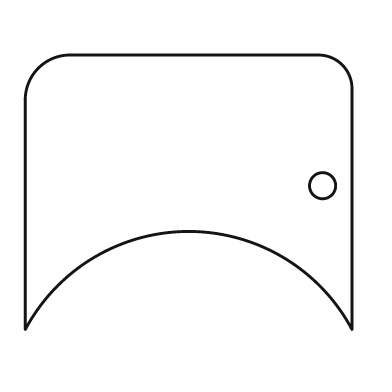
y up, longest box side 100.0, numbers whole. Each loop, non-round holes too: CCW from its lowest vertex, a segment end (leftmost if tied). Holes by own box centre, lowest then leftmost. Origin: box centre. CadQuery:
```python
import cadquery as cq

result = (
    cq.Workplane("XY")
    .moveTo(-50.0, -42.0)
    .threePointArc((0.0, -12.0), (50.0, -42.0))
    .lineTo(50.0, 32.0)
    .threePointArc((47.0, 39.0), (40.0, 42.0))
    .lineTo(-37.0, 42.0)
    .threePointArc((-46.0, 38.0), (-50.0, 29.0))
    .close()
    .moveTo(41.0, 2.0)
    .circle(4.0)
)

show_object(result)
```